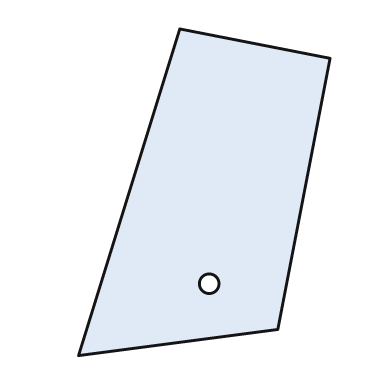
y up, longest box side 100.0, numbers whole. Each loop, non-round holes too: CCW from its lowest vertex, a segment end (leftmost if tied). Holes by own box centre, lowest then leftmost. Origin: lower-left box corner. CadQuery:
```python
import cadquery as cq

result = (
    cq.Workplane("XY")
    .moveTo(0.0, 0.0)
    .lineTo(61.0, 8.0)
    .lineTo(77.0, 91.0)
    .lineTo(31.0, 100.0)
    .close()
    .moveTo(40.0, 22.0)
    .circle(3.0)
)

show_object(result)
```